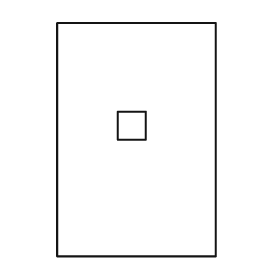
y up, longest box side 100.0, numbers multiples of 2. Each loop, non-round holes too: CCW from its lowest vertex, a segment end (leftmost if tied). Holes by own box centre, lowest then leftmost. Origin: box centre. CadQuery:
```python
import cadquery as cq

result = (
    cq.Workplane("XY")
    .moveTo(-34.0, -50.0)
    .lineTo(34.0, -50.0)
    .lineTo(34.0, 50.0)
    .lineTo(-34.0, 50.0)
    .close()
    .moveTo(-8.0, 0.0)
    .lineTo(4.0, 0.0)
    .lineTo(4.0, 12.0)
    .lineTo(-8.0, 12.0)
    .close()
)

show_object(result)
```